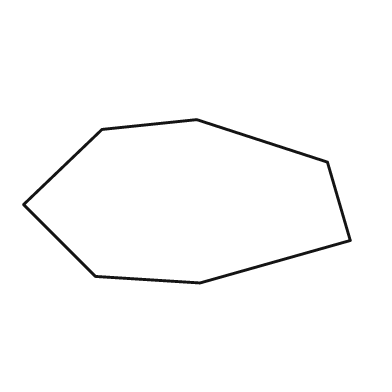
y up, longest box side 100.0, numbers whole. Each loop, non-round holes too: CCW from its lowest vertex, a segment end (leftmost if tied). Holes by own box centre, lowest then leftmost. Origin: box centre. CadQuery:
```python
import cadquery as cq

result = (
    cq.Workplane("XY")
    .moveTo(4.0, -25.0)
    .lineTo(50.0, -12.0)
    .lineTo(43.0, 12.0)
    .lineTo(3.0, 25.0)
    .lineTo(-26.0, 22.0)
    .lineTo(-50.0, -1.0)
    .lineTo(-28.0, -23.0)
    .close()
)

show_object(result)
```